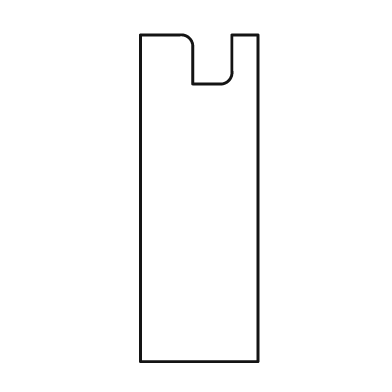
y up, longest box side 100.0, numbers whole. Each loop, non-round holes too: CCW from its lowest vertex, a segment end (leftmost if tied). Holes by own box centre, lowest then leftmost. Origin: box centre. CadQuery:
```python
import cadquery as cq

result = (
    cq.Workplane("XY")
    .moveTo(-18.0, -50.0)
    .lineTo(18.0, -50.0)
    .lineTo(18.0, 50.0)
    .lineTo(10.0, 50.0)
    .lineTo(10.0, 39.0)
    .threePointArc((9.0, 36.0), (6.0, 35.0))
    .lineTo(-2.0, 35.0)
    .lineTo(-2.0, 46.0)
    .threePointArc((-3.0, 49.0), (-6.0, 50.0))
    .lineTo(-18.0, 50.0)
    .close()
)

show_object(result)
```